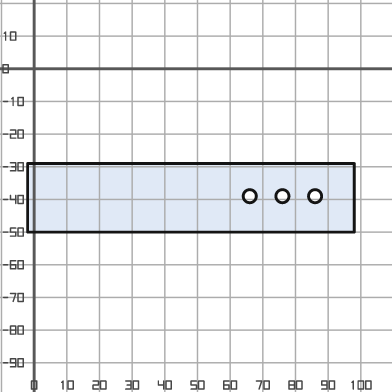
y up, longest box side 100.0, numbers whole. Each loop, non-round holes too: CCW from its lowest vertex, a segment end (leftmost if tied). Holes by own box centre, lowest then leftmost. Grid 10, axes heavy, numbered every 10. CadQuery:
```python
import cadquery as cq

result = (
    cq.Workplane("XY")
    .moveTo(-2.0, -50.0)
    .lineTo(98.0, -50.0)
    .lineTo(98.0, -29.0)
    .lineTo(-2.0, -29.0)
    .close()
    .moveTo(66.0, -39.0)
    .circle(2.0)
    .moveTo(76.0, -39.0)
    .circle(2.0)
    .moveTo(86.0, -39.0)
    .circle(2.0)
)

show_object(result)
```